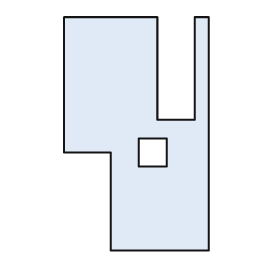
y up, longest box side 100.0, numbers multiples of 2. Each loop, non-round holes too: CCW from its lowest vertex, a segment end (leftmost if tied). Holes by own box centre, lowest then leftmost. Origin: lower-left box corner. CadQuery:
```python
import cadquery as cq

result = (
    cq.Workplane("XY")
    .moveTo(20.0, 0.0)
    .lineTo(62.0, 0.0)
    .lineTo(62.0, 100.0)
    .lineTo(56.0, 100.0)
    .lineTo(56.0, 56.0)
    .lineTo(40.0, 56.0)
    .lineTo(40.0, 100.0)
    .lineTo(0.0, 100.0)
    .lineTo(0.0, 42.0)
    .lineTo(20.0, 42.0)
    .close()
    .moveTo(32.0, 36.0)
    .lineTo(44.0, 36.0)
    .lineTo(44.0, 48.0)
    .lineTo(32.0, 48.0)
    .close()
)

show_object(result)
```